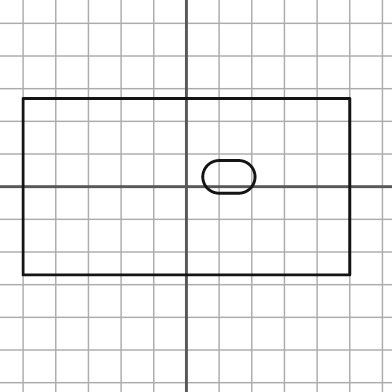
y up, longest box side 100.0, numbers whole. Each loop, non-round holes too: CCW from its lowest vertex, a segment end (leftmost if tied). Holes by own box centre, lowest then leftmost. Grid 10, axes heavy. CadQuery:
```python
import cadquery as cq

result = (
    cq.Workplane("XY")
    .moveTo(-50.0, -27.0)
    .lineTo(50.0, -27.0)
    .lineTo(50.0, 27.0)
    .lineTo(-50.0, 27.0)
    .close()
    .moveTo(10.0, -2.0)
    .lineTo(16.0, -2.0)
    .threePointArc((21.0, 3.0), (16.0, 8.0))
    .lineTo(10.0, 8.0)
    .threePointArc((5.0, 3.0), (10.0, -2.0))
    .close()
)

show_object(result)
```